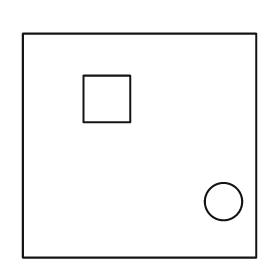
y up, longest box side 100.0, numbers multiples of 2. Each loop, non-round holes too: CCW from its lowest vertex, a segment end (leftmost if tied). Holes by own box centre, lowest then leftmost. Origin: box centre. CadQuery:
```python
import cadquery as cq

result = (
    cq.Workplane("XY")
    .moveTo(-50.0, -48.0)
    .lineTo(50.0, -48.0)
    .lineTo(50.0, 48.0)
    .lineTo(-50.0, 48.0)
    .close()
    .moveTo(36.0, -24.0)
    .circle(8.0)
    .moveTo(-24.0, 10.0)
    .lineTo(-4.0, 10.0)
    .lineTo(-4.0, 30.0)
    .lineTo(-24.0, 30.0)
    .close()
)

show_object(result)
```